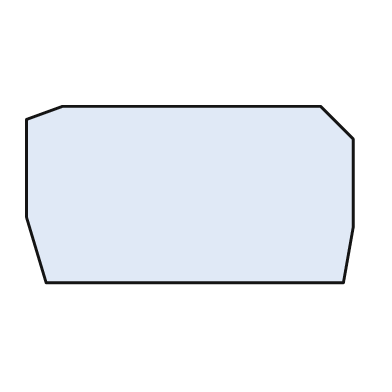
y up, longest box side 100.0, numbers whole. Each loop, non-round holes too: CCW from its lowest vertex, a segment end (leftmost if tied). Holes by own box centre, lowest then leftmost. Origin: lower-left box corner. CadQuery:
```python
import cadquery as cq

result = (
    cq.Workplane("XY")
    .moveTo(6.0, 0.0)
    .lineTo(97.0, 0.0)
    .lineTo(100.0, 17.0)
    .lineTo(100.0, 44.0)
    .lineTo(90.0, 54.0)
    .lineTo(11.0, 54.0)
    .lineTo(0.0, 50.0)
    .lineTo(0.0, 20.0)
    .close()
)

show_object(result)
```